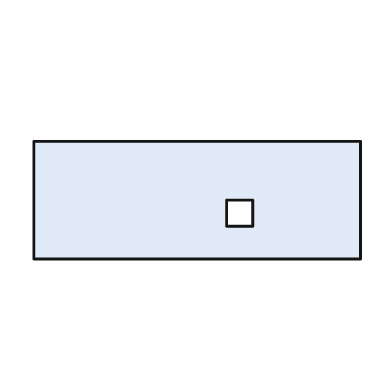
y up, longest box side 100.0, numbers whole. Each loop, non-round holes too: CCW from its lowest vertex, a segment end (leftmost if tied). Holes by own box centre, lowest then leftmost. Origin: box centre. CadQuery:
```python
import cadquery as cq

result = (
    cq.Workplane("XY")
    .moveTo(-50.0, -18.0)
    .lineTo(50.0, -18.0)
    .lineTo(50.0, 18.0)
    .lineTo(-50.0, 18.0)
    .close()
    .moveTo(9.0, -8.0)
    .lineTo(17.0, -8.0)
    .lineTo(17.0, 0.0)
    .lineTo(9.0, 0.0)
    .close()
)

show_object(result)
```